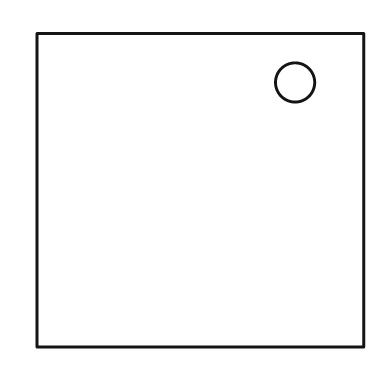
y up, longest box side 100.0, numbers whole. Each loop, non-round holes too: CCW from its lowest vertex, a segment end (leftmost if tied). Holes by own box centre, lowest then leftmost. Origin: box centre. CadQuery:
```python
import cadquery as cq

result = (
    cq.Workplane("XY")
    .moveTo(-50.0, -48.0)
    .lineTo(50.0, -48.0)
    .lineTo(50.0, 48.0)
    .lineTo(-50.0, 48.0)
    .close()
    .moveTo(29.0, 33.0)
    .circle(6.0)
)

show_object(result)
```